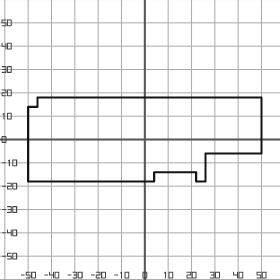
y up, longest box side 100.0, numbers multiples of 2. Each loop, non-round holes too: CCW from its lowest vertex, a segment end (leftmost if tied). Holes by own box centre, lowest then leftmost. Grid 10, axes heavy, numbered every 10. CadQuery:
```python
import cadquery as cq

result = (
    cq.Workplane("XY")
    .moveTo(-50.0, -18.0)
    .lineTo(4.0, -18.0)
    .lineTo(4.0, -14.0)
    .lineTo(22.0, -14.0)
    .lineTo(22.0, -18.0)
    .lineTo(26.0, -18.0)
    .lineTo(26.0, -6.0)
    .lineTo(50.0, -6.0)
    .lineTo(50.0, 18.0)
    .lineTo(-46.0, 18.0)
    .lineTo(-46.0, 14.0)
    .lineTo(-50.0, 14.0)
    .close()
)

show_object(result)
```